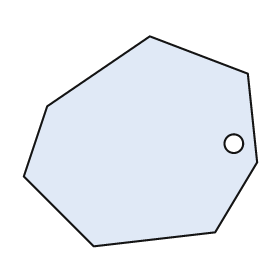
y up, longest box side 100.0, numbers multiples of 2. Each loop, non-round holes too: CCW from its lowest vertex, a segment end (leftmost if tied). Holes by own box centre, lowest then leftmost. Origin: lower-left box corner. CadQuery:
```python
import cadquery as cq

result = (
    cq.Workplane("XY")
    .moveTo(30.0, 0.0)
    .lineTo(82.0, 6.0)
    .lineTo(100.0, 36.0)
    .lineTo(96.0, 74.0)
    .lineTo(54.0, 90.0)
    .lineTo(10.0, 60.0)
    .lineTo(0.0, 30.0)
    .close()
    .moveTo(90.0, 44.0)
    .circle(4.0)
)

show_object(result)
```